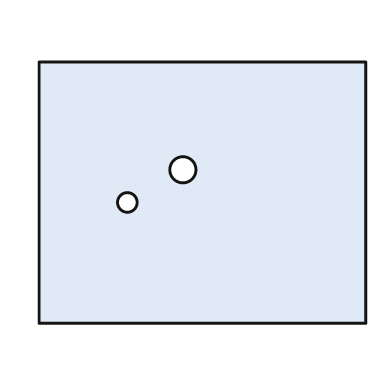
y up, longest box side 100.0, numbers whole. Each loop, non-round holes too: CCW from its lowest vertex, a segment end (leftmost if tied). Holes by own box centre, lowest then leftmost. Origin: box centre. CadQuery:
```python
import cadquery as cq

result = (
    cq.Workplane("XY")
    .moveTo(-50.0, -40.0)
    .lineTo(50.0, -40.0)
    .lineTo(50.0, 40.0)
    .lineTo(-50.0, 40.0)
    .close()
    .moveTo(-23.0, -3.0)
    .circle(3.0)
    .moveTo(-6.0, 7.0)
    .circle(4.0)
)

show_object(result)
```